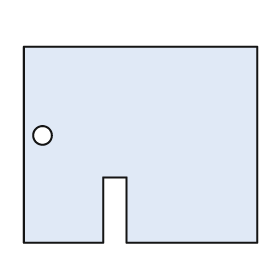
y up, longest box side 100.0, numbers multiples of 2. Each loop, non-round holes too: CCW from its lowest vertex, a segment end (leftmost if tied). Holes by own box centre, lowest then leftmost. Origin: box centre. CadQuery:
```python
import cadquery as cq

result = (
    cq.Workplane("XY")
    .moveTo(-50.0, -42.0)
    .lineTo(-16.0, -42.0)
    .lineTo(-16.0, -14.0)
    .lineTo(-6.0, -14.0)
    .lineTo(-6.0, -42.0)
    .lineTo(50.0, -42.0)
    .lineTo(50.0, 42.0)
    .lineTo(-50.0, 42.0)
    .close()
    .moveTo(-42.0, 4.0)
    .circle(4.0)
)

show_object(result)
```